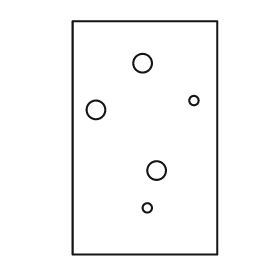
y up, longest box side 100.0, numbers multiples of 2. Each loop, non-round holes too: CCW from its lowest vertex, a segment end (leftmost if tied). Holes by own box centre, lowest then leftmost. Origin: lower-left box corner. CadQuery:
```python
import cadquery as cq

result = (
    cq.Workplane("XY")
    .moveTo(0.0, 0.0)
    .lineTo(62.0, 0.0)
    .lineTo(62.0, 100.0)
    .lineTo(0.0, 100.0)
    .close()
    .moveTo(32.0, 20.0)
    .circle(2.0)
    .moveTo(36.0, 36.0)
    .circle(4.0)
    .moveTo(10.0, 62.0)
    .circle(4.0)
    .moveTo(52.0, 66.0)
    .circle(2.0)
    .moveTo(30.0, 82.0)
    .circle(4.0)
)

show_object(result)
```